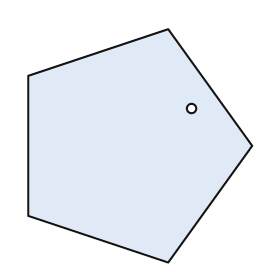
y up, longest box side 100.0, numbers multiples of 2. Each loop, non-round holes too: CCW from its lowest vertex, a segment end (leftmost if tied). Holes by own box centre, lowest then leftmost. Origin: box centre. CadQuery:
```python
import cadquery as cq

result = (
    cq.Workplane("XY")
    .moveTo(12.0, -50.0)
    .lineTo(48.0, 0.0)
    .lineTo(12.0, 50.0)
    .lineTo(-48.0, 30.0)
    .lineTo(-48.0, -30.0)
    .close()
    .moveTo(22.0, 16.0)
    .circle(2.0)
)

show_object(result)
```